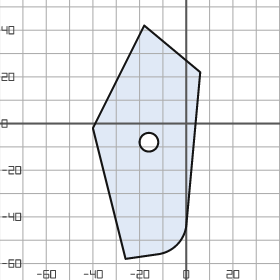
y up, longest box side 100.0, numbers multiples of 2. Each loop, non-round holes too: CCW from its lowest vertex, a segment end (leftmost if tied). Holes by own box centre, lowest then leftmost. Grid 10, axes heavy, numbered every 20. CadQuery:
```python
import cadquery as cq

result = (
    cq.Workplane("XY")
    .moveTo(-26.0, -58.0)
    .lineTo(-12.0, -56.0)
    .threePointArc((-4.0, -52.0), (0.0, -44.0))
    .lineTo(6.0, 22.0)
    .lineTo(-18.0, 42.0)
    .lineTo(-40.0, -2.0)
    .close()
    .moveTo(-16.0, -8.0)
    .circle(4.0)
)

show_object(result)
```